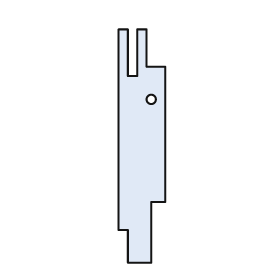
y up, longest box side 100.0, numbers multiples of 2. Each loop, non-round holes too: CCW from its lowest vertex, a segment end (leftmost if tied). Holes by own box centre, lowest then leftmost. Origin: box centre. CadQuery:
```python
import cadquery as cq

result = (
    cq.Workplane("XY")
    .moveTo(-6.0, -50.0)
    .lineTo(4.0, -50.0)
    .lineTo(4.0, -24.0)
    .lineTo(10.0, -24.0)
    .lineTo(10.0, 34.0)
    .lineTo(2.0, 34.0)
    .lineTo(2.0, 50.0)
    .lineTo(-2.0, 50.0)
    .lineTo(-2.0, 30.0)
    .lineTo(-6.0, 30.0)
    .lineTo(-6.0, 50.0)
    .lineTo(-10.0, 50.0)
    .lineTo(-10.0, -36.0)
    .lineTo(-6.0, -36.0)
    .close()
    .moveTo(4.0, 20.0)
    .circle(2.0)
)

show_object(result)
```